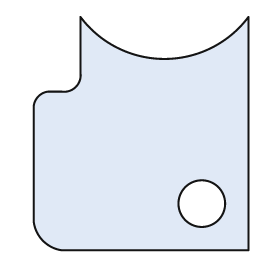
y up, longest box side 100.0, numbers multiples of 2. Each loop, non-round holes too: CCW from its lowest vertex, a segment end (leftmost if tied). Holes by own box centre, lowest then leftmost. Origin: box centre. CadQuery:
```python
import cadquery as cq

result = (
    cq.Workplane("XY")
    .moveTo(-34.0, -50.0)
    .lineTo(46.0, -50.0)
    .lineTo(46.0, 50.0)
    .threePointArc((10.0, 32.0), (-26.0, 50.0))
    .lineTo(-26.0, 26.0)
    .threePointArc((-28.0, 20.0), (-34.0, 18.0))
    .lineTo(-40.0, 18.0)
    .threePointArc((-44.0, 16.0), (-46.0, 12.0))
    .lineTo(-46.0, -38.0)
    .threePointArc((-42.0, -46.0), (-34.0, -50.0))
    .close()
    .moveTo(26.0, -30.0)
    .circle(10.0)
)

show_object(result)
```